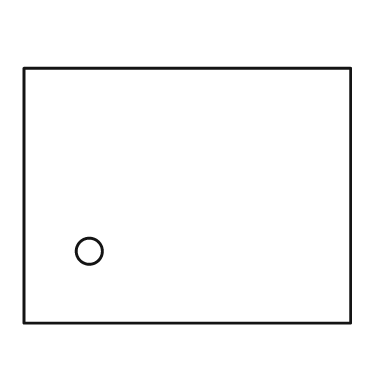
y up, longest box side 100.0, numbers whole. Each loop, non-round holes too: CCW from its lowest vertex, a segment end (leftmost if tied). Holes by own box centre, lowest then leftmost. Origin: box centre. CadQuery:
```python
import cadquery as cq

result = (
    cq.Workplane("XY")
    .moveTo(-50.0, -39.0)
    .lineTo(50.0, -39.0)
    .lineTo(50.0, 39.0)
    .lineTo(-50.0, 39.0)
    .close()
    .moveTo(-30.0, -17.0)
    .circle(4.0)
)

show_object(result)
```